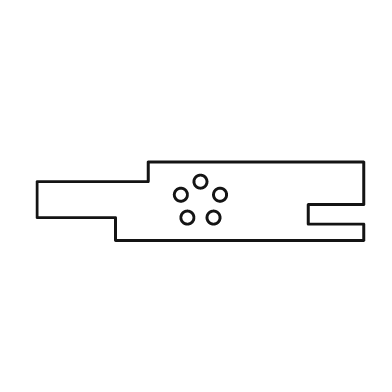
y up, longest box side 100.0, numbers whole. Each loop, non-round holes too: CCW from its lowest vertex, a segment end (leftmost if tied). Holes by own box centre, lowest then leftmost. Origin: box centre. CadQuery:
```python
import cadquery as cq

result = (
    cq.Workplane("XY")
    .moveTo(-26.0, -12.0)
    .lineTo(50.0, -12.0)
    .lineTo(50.0, -7.0)
    .lineTo(33.0, -7.0)
    .lineTo(33.0, -1.0)
    .lineTo(50.0, -1.0)
    .lineTo(50.0, 12.0)
    .lineTo(-16.0, 12.0)
    .lineTo(-16.0, 6.0)
    .lineTo(-50.0, 6.0)
    .lineTo(-50.0, -5.0)
    .lineTo(-26.0, -5.0)
    .close()
    .moveTo(-4.0, -5.0)
    .circle(2.0)
    .moveTo(4.0, -5.0)
    .circle(2.0)
    .moveTo(-6.0, 2.0)
    .circle(2.0)
    .moveTo(6.0, 2.0)
    .circle(2.0)
    .moveTo(0.0, 6.0)
    .circle(2.0)
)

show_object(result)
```